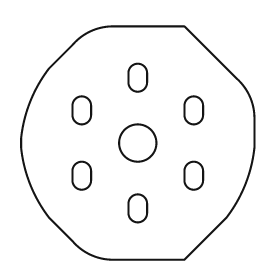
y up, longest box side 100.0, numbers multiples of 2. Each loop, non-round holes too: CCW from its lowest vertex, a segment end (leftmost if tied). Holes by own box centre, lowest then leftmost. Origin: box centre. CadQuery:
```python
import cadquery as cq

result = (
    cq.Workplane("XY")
    .moveTo(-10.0, -50.0)
    .lineTo(20.0, -50.0)
    .lineTo(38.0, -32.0)
    .threePointArc((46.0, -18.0), (50.0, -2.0))
    .lineTo(50.0, 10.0)
    .threePointArc((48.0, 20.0), (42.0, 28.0))
    .lineTo(20.0, 50.0)
    .lineTo(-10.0, 50.0)
    .threePointArc((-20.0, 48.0), (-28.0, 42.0))
    .lineTo(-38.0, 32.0)
    .threePointArc((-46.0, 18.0), (-50.0, 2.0))
    .lineTo(-50.0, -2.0)
    .threePointArc((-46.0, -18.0), (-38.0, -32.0))
    .lineTo(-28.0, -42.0)
    .threePointArc((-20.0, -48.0), (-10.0, -50.0))
    .close()
    .moveTo(-4.0, -30.0)
    .threePointArc((0.0, -34.0), (4.0, -30.0))
    .lineTo(4.0, -26.0)
    .threePointArc((0.0, -22.0), (-4.0, -26.0))
    .close()
    .moveTo(-28.0, -16.0)
    .threePointArc((-24.0, -20.0), (-20.0, -16.0))
    .lineTo(-20.0, -12.0)
    .threePointArc((-24.0, -8.0), (-28.0, -12.0))
    .close()
    .moveTo(20.0, -16.0)
    .threePointArc((24.0, -20.0), (28.0, -16.0))
    .lineTo(28.0, -12.0)
    .threePointArc((24.0, -8.0), (20.0, -12.0))
    .close()
    .moveTo(0.0, 0.0)
    .circle(8.0)
    .moveTo(-28.0, 12.0)
    .threePointArc((-24.0, 8.0), (-20.0, 12.0))
    .lineTo(-20.0, 16.0)
    .threePointArc((-24.0, 20.0), (-28.0, 16.0))
    .close()
    .moveTo(20.0, 12.0)
    .threePointArc((24.0, 8.0), (28.0, 12.0))
    .lineTo(28.0, 16.0)
    .threePointArc((24.0, 20.0), (20.0, 16.0))
    .close()
    .moveTo(-4.0, 26.0)
    .threePointArc((0.0, 22.0), (4.0, 26.0))
    .lineTo(4.0, 30.0)
    .threePointArc((0.0, 34.0), (-4.0, 30.0))
    .close()
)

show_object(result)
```